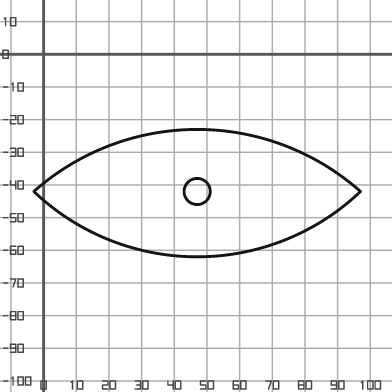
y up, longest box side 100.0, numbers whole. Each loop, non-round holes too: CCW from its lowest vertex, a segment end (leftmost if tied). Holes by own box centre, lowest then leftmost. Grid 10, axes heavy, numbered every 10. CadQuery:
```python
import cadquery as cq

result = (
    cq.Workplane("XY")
    .moveTo(-3.0, -42.0)
    .threePointArc((47.0, -62.0), (97.0, -42.0))
    .threePointArc((47.0, -23.0), (-3.0, -42.0))
    .close()
    .moveTo(47.0, -42.0)
    .circle(4.0)
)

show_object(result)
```